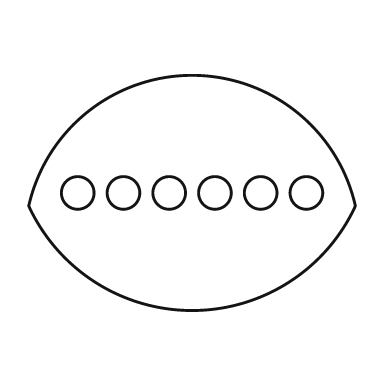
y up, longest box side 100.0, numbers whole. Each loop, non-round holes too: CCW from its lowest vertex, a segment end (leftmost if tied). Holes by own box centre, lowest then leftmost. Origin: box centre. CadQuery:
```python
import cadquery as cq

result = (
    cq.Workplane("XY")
    .moveTo(-50.0, -4.0)
    .threePointArc((0.0, -36.0), (50.0, -4.0))
    .threePointArc((0.0, 36.0), (-50.0, -4.0))
    .close()
    .moveTo(-35.0, 0.0)
    .circle(5.0)
    .moveTo(-21.0, 0.0)
    .circle(5.0)
    .moveTo(-7.0, 0.0)
    .circle(5.0)
    .moveTo(7.0, 0.0)
    .circle(5.0)
    .moveTo(21.0, 0.0)
    .circle(5.0)
    .moveTo(35.0, 0.0)
    .circle(5.0)
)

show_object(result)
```